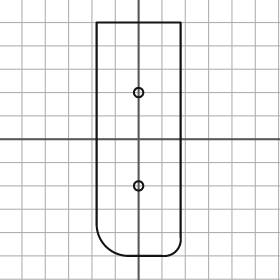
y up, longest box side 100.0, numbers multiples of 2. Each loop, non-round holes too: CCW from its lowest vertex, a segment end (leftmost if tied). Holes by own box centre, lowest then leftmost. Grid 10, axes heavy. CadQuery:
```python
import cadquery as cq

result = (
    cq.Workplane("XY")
    .moveTo(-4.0, -50.0)
    .lineTo(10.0, -50.0)
    .threePointArc((16.0, -48.0), (18.0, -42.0))
    .lineTo(18.0, 50.0)
    .lineTo(-18.0, 50.0)
    .lineTo(-18.0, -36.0)
    .threePointArc((-14.0, -46.0), (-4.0, -50.0))
    .close()
    .moveTo(0.0, -20.0)
    .circle(2.0)
    .moveTo(0.0, 20.0)
    .circle(2.0)
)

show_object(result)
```